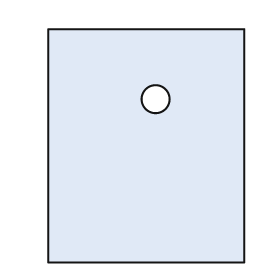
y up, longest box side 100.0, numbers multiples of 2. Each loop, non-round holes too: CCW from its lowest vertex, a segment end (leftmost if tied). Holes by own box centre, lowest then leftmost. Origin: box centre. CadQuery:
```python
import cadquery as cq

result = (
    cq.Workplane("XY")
    .moveTo(-42.0, -50.0)
    .lineTo(42.0, -50.0)
    .lineTo(42.0, 50.0)
    .lineTo(-42.0, 50.0)
    .close()
    .moveTo(4.0, 20.0)
    .circle(6.0)
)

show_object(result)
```